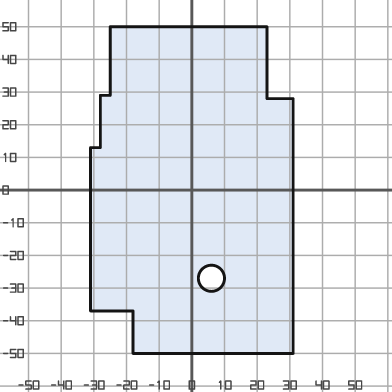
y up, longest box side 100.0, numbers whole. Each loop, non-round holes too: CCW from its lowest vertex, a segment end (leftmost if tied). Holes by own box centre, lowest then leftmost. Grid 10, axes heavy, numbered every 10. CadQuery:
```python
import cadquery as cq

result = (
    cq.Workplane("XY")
    .moveTo(-18.0, -50.0)
    .lineTo(31.0, -50.0)
    .lineTo(31.0, 28.0)
    .lineTo(23.0, 28.0)
    .lineTo(23.0, 50.0)
    .lineTo(-25.0, 50.0)
    .lineTo(-25.0, 29.0)
    .lineTo(-28.0, 29.0)
    .lineTo(-28.0, 13.0)
    .lineTo(-31.0, 13.0)
    .lineTo(-31.0, -37.0)
    .lineTo(-18.0, -37.0)
    .close()
    .moveTo(6.0, -27.0)
    .circle(4.0)
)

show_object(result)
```